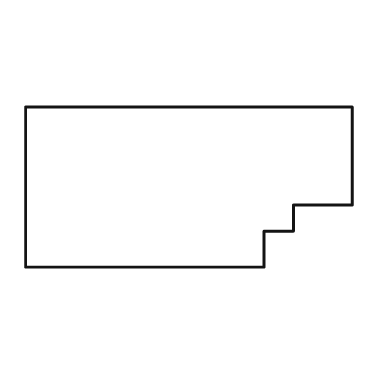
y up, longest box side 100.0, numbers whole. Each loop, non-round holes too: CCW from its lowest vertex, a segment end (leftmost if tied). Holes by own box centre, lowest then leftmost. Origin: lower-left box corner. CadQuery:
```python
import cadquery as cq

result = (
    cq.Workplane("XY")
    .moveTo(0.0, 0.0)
    .lineTo(73.0, 0.0)
    .lineTo(73.0, 11.0)
    .lineTo(82.0, 11.0)
    .lineTo(82.0, 19.0)
    .lineTo(100.0, 19.0)
    .lineTo(100.0, 49.0)
    .lineTo(0.0, 49.0)
    .close()
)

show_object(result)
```